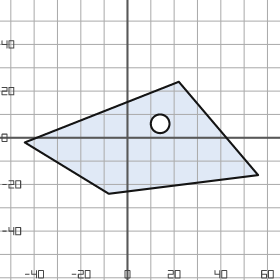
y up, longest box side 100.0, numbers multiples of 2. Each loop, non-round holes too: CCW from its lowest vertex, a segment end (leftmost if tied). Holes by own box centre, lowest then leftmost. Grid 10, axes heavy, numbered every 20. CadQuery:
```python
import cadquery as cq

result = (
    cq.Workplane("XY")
    .moveTo(-8.0, -24.0)
    .lineTo(56.0, -16.0)
    .lineTo(22.0, 24.0)
    .lineTo(-44.0, -2.0)
    .close()
    .moveTo(14.0, 6.0)
    .circle(4.0)
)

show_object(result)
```